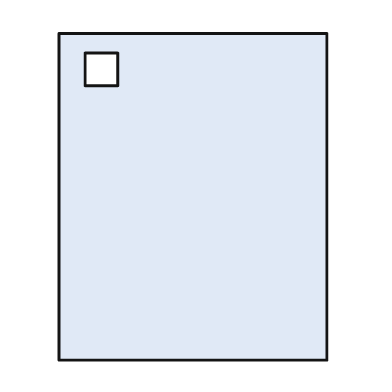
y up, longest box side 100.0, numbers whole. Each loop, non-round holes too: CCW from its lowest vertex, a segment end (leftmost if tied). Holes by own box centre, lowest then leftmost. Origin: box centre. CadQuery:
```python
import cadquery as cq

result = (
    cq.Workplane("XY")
    .moveTo(-41.0, -50.0)
    .lineTo(41.0, -50.0)
    .lineTo(41.0, 50.0)
    .lineTo(-41.0, 50.0)
    .close()
    .moveTo(-33.0, 34.0)
    .lineTo(-23.0, 34.0)
    .lineTo(-23.0, 44.0)
    .lineTo(-33.0, 44.0)
    .close()
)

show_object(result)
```